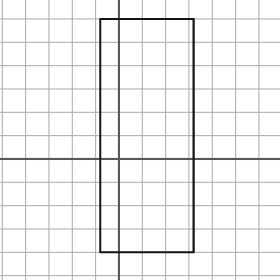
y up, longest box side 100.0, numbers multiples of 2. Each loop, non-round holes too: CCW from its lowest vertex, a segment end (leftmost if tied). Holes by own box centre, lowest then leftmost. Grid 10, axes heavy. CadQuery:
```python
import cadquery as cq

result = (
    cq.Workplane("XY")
    .moveTo(-8.0, -40.0)
    .lineTo(32.0, -40.0)
    .lineTo(32.0, 60.0)
    .lineTo(-8.0, 60.0)
    .close()
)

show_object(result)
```